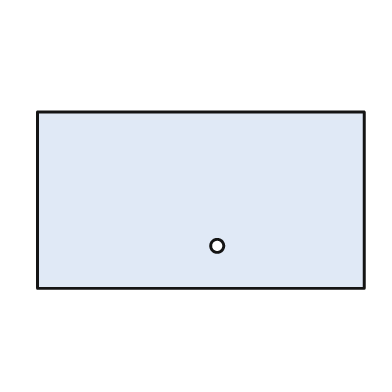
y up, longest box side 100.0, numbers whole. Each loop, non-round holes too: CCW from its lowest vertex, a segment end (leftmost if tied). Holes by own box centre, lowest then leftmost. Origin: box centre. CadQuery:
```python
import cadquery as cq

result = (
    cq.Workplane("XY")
    .moveTo(-50.0, -27.0)
    .lineTo(50.0, -27.0)
    .lineTo(50.0, 27.0)
    .lineTo(-50.0, 27.0)
    .close()
    .moveTo(5.0, -14.0)
    .circle(2.0)
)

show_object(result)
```